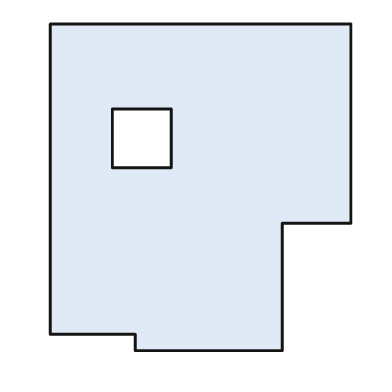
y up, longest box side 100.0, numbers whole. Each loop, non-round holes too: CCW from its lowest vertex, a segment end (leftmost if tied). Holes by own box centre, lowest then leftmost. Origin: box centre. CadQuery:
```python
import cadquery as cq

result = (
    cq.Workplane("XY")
    .moveTo(-20.0, -50.0)
    .lineTo(25.0, -50.0)
    .lineTo(25.0, -11.0)
    .lineTo(46.0, -11.0)
    .lineTo(46.0, 50.0)
    .lineTo(-46.0, 50.0)
    .lineTo(-46.0, -45.0)
    .lineTo(-20.0, -45.0)
    .close()
    .moveTo(-27.0, 6.0)
    .lineTo(-9.0, 6.0)
    .lineTo(-9.0, 24.0)
    .lineTo(-27.0, 24.0)
    .close()
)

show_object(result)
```